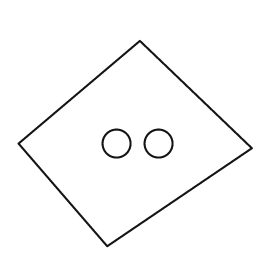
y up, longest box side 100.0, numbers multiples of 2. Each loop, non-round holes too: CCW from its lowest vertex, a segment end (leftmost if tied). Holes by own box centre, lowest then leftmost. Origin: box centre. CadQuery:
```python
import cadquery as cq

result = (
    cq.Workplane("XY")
    .moveTo(-12.0, -44.0)
    .lineTo(50.0, -2.0)
    .lineTo(2.0, 44.0)
    .lineTo(-50.0, 0.0)
    .close()
    .moveTo(-8.0, 0.0)
    .circle(6.0)
    .moveTo(10.0, 0.0)
    .circle(6.0)
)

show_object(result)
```